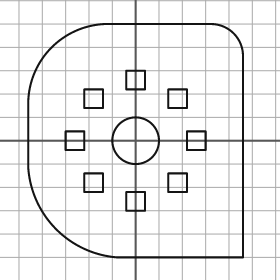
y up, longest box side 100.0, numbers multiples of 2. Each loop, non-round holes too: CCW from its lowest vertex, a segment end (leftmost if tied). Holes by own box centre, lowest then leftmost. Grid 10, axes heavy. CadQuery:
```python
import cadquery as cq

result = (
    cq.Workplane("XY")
    .moveTo(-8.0, -50.0)
    .lineTo(46.0, -50.0)
    .lineTo(46.0, 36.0)
    .threePointArc((42.0, 46.0), (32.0, 50.0))
    .lineTo(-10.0, 50.0)
    .threePointArc((-36.0, 40.0), (-46.0, 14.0))
    .lineTo(-46.0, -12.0)
    .threePointArc((-34.0, -38.0), (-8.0, -50.0))
    .close()
    .moveTo(-4.0, -30.0)
    .lineTo(4.0, -30.0)
    .lineTo(4.0, -22.0)
    .lineTo(-4.0, -22.0)
    .close()
    .moveTo(-22.0, -22.0)
    .lineTo(-14.0, -22.0)
    .lineTo(-14.0, -14.0)
    .lineTo(-22.0, -14.0)
    .close()
    .moveTo(14.0, -22.0)
    .lineTo(22.0, -22.0)
    .lineTo(22.0, -14.0)
    .lineTo(14.0, -14.0)
    .close()
    .moveTo(-30.0, -4.0)
    .lineTo(-22.0, -4.0)
    .lineTo(-22.0, 4.0)
    .lineTo(-30.0, 4.0)
    .close()
    .moveTo(0.0, 0.0)
    .circle(10.0)
    .moveTo(22.0, -4.0)
    .lineTo(30.0, -4.0)
    .lineTo(30.0, 4.0)
    .lineTo(22.0, 4.0)
    .close()
    .moveTo(-22.0, 14.0)
    .lineTo(-14.0, 14.0)
    .lineTo(-14.0, 22.0)
    .lineTo(-22.0, 22.0)
    .close()
    .moveTo(14.0, 14.0)
    .lineTo(22.0, 14.0)
    .lineTo(22.0, 22.0)
    .lineTo(14.0, 22.0)
    .close()
    .moveTo(-4.0, 22.0)
    .lineTo(4.0, 22.0)
    .lineTo(4.0, 30.0)
    .lineTo(-4.0, 30.0)
    .close()
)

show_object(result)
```